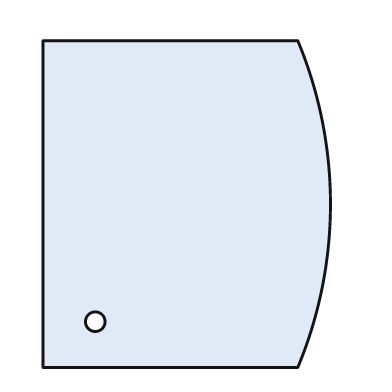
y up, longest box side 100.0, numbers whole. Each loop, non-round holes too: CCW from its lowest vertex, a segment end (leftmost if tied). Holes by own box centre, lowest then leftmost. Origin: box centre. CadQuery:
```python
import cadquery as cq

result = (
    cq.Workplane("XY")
    .moveTo(-44.0, -50.0)
    .lineTo(34.0, -50.0)
    .threePointArc((44.0, 0.0), (34.0, 50.0))
    .lineTo(-44.0, 50.0)
    .close()
    .moveTo(-28.0, -36.0)
    .circle(3.0)
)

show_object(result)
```